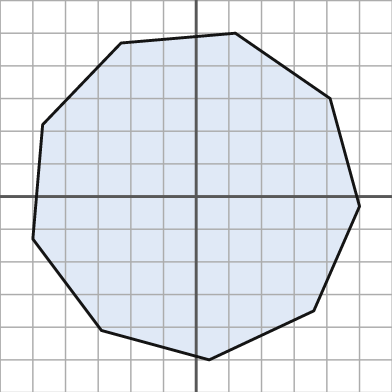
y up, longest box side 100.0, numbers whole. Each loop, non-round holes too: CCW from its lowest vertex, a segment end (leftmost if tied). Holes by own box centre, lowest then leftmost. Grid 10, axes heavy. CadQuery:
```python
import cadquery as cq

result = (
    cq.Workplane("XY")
    .moveTo(4.0, -50.0)
    .lineTo(36.0, -35.0)
    .lineTo(50.0, -3.0)
    .lineTo(41.0, 30.0)
    .lineTo(12.0, 50.0)
    .lineTo(-23.0, 47.0)
    .lineTo(-47.0, 22.0)
    .lineTo(-50.0, -13.0)
    .lineTo(-29.0, -41.0)
    .close()
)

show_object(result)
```